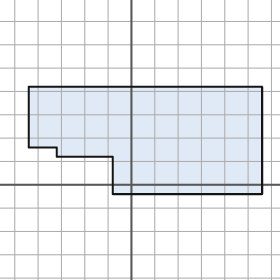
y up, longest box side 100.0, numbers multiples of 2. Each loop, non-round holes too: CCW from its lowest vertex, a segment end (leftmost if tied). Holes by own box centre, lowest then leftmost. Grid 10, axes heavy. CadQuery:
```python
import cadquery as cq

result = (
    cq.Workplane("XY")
    .moveTo(-8.0, -4.0)
    .lineTo(56.0, -4.0)
    .lineTo(56.0, 42.0)
    .lineTo(-44.0, 42.0)
    .lineTo(-44.0, 16.0)
    .lineTo(-32.0, 16.0)
    .lineTo(-32.0, 12.0)
    .lineTo(-8.0, 12.0)
    .close()
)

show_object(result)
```